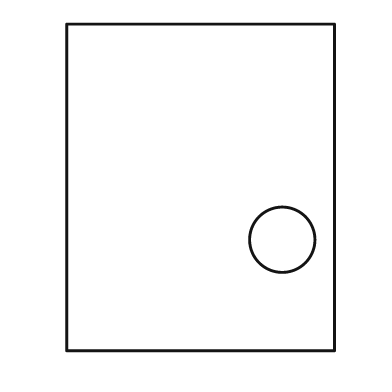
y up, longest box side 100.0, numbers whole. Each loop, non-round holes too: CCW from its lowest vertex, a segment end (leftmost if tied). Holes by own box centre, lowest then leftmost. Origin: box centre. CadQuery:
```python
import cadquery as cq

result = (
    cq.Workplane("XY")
    .moveTo(-41.0, -50.0)
    .lineTo(41.0, -50.0)
    .lineTo(41.0, 50.0)
    .lineTo(-41.0, 50.0)
    .close()
    .moveTo(25.0, -16.0)
    .circle(10.0)
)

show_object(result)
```